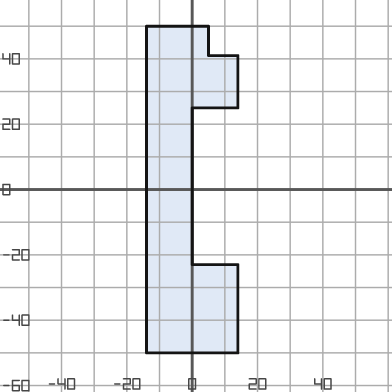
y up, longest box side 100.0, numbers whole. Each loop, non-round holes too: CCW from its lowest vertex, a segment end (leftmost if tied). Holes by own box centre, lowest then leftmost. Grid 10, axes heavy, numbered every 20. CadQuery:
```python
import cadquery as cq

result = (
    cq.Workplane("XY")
    .moveTo(-14.0, -50.0)
    .lineTo(14.0, -50.0)
    .lineTo(14.0, -23.0)
    .lineTo(0.0, -23.0)
    .lineTo(0.0, 25.0)
    .lineTo(14.0, 25.0)
    .lineTo(14.0, 41.0)
    .lineTo(5.0, 41.0)
    .lineTo(5.0, 50.0)
    .lineTo(-14.0, 50.0)
    .close()
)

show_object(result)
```